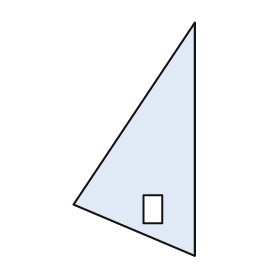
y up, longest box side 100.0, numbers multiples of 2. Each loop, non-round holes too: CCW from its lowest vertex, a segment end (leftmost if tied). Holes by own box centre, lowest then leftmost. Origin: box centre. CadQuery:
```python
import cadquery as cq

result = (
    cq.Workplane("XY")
    .moveTo(26.0, -50.0)
    .lineTo(26.0, 50.0)
    .lineTo(-26.0, -28.0)
    .close()
    .moveTo(4.0, -36.0)
    .lineTo(12.0, -36.0)
    .lineTo(12.0, -24.0)
    .lineTo(4.0, -24.0)
    .close()
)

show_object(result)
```